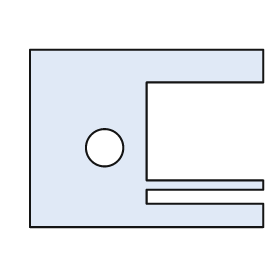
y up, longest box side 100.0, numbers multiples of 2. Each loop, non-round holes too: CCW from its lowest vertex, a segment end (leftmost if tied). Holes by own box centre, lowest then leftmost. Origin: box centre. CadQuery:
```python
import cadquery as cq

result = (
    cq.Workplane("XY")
    .moveTo(-50.0, -38.0)
    .lineTo(50.0, -38.0)
    .lineTo(50.0, -28.0)
    .lineTo(0.0, -28.0)
    .lineTo(0.0, -22.0)
    .lineTo(50.0, -22.0)
    .lineTo(50.0, -18.0)
    .lineTo(0.0, -18.0)
    .lineTo(0.0, 24.0)
    .lineTo(50.0, 24.0)
    .lineTo(50.0, 38.0)
    .lineTo(-50.0, 38.0)
    .close()
    .moveTo(-18.0, -4.0)
    .circle(8.0)
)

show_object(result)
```